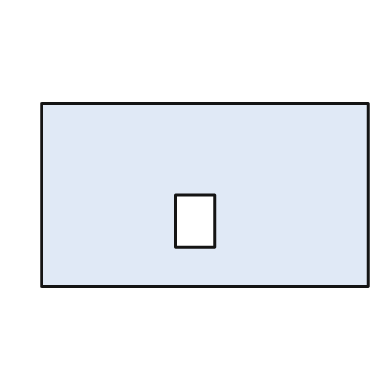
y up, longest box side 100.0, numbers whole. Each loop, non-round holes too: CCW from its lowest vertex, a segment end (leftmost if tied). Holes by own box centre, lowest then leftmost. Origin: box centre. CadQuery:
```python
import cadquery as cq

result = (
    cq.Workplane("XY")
    .moveTo(-50.0, -28.0)
    .lineTo(50.0, -28.0)
    .lineTo(50.0, 28.0)
    .lineTo(-50.0, 28.0)
    .close()
    .moveTo(-9.0, -16.0)
    .lineTo(3.0, -16.0)
    .lineTo(3.0, 0.0)
    .lineTo(-9.0, 0.0)
    .close()
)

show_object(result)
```